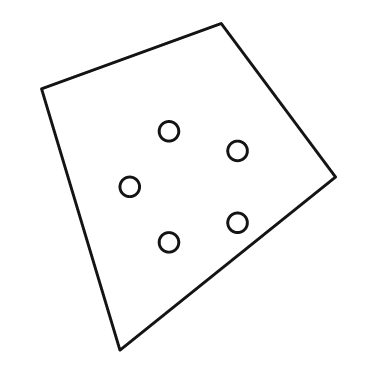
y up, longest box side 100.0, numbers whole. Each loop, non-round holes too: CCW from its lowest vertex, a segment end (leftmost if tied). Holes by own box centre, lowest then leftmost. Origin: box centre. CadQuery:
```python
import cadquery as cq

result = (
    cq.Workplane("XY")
    .moveTo(-21.0, -50.0)
    .lineTo(45.0, 3.0)
    .lineTo(10.0, 50.0)
    .lineTo(-45.0, 30.0)
    .close()
    .moveTo(-6.0, -17.0)
    .circle(3.0)
    .moveTo(15.0, -11.0)
    .circle(3.0)
    .moveTo(-18.0, 0.0)
    .circle(3.0)
    .moveTo(15.0, 11.0)
    .circle(3.0)
    .moveTo(-6.0, 17.0)
    .circle(3.0)
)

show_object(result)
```